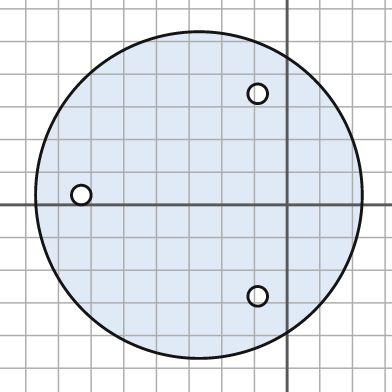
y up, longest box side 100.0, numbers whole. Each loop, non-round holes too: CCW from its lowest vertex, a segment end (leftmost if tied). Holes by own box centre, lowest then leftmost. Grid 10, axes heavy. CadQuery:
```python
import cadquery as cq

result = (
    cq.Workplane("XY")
    .moveTo(-27.0, 3.0)
    .circle(50.0)
    .moveTo(-9.0, -28.0)
    .circle(3.0)
    .moveTo(-63.0, 3.0)
    .circle(3.0)
    .moveTo(-9.0, 34.0)
    .circle(3.0)
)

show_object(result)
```